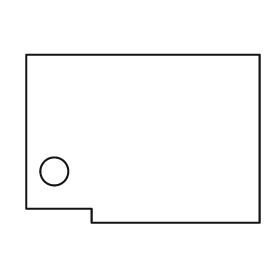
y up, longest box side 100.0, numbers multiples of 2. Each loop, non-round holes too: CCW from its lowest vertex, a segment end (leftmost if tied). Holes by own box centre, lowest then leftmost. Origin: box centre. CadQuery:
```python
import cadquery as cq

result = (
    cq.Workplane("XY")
    .moveTo(-22.0, -36.0)
    .lineTo(50.0, -36.0)
    .lineTo(50.0, 36.0)
    .lineTo(-50.0, 36.0)
    .lineTo(-50.0, -30.0)
    .lineTo(-22.0, -30.0)
    .close()
    .moveTo(-38.0, -14.0)
    .circle(6.0)
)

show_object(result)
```